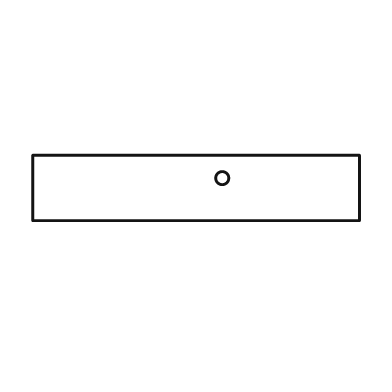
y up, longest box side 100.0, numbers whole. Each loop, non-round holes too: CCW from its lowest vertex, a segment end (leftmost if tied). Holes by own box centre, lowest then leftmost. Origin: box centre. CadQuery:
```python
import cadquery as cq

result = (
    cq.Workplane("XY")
    .moveTo(-50.0, -10.0)
    .lineTo(50.0, -10.0)
    .lineTo(50.0, 10.0)
    .lineTo(-50.0, 10.0)
    .close()
    .moveTo(8.0, 3.0)
    .circle(2.0)
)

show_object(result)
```